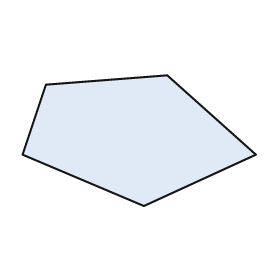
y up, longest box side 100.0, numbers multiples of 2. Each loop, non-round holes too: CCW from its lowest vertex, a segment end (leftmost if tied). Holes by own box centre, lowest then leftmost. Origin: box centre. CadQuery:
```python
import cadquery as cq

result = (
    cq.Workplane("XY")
    .moveTo(2.0, -28.0)
    .lineTo(50.0, -6.0)
    .lineTo(12.0, 28.0)
    .lineTo(-40.0, 24.0)
    .lineTo(-50.0, -6.0)
    .close()
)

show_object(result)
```